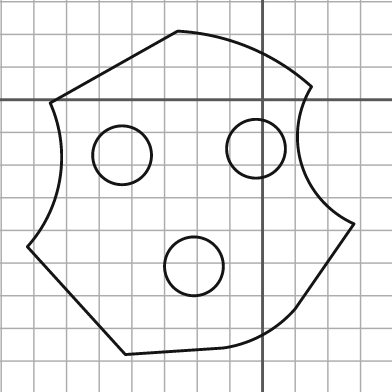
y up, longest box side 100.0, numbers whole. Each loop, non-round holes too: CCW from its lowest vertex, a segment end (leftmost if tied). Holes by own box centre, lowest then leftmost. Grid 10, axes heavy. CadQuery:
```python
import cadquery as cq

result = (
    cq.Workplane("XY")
    .moveTo(-42.0, -78.0)
    .lineTo(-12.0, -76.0)
    .threePointArc((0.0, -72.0), (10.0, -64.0))
    .lineTo(28.0, -38.0)
    .threePointArc((12.0, -20.0), (15.0, 4.0))
    .threePointArc((-4.0, 16.0), (-26.0, 21.0))
    .lineTo(-65.0, -1.0)
    .threePointArc((-62.0, -24.0), (-72.0, -45.0))
    .close()
    .moveTo(-21.0, -51.0)
    .circle(9.0)
    .moveTo(-43.0, -17.0)
    .circle(9.0)
    .moveTo(-2.0, -15.0)
    .circle(9.0)
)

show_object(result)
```